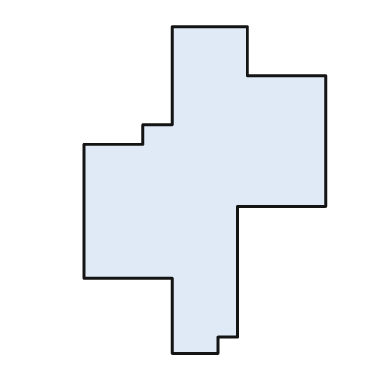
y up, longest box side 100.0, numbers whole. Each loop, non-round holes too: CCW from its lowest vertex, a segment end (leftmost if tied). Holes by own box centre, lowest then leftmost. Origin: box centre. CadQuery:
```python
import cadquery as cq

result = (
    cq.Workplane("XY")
    .moveTo(-10.0, -50.0)
    .lineTo(4.0, -50.0)
    .lineTo(4.0, -45.0)
    .lineTo(10.0, -45.0)
    .lineTo(10.0, -5.0)
    .lineTo(37.0, -5.0)
    .lineTo(37.0, 35.0)
    .lineTo(13.0, 35.0)
    .lineTo(13.0, 50.0)
    .lineTo(-10.0, 50.0)
    .lineTo(-10.0, 20.0)
    .lineTo(-19.0, 20.0)
    .lineTo(-19.0, 14.0)
    .lineTo(-37.0, 14.0)
    .lineTo(-37.0, -27.0)
    .lineTo(-10.0, -27.0)
    .close()
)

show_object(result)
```